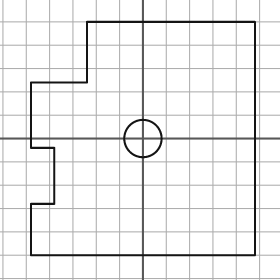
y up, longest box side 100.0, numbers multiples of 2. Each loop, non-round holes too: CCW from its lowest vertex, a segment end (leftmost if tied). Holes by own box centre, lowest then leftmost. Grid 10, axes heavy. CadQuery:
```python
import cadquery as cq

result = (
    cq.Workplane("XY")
    .moveTo(-48.0, -50.0)
    .lineTo(48.0, -50.0)
    .lineTo(48.0, 50.0)
    .lineTo(-24.0, 50.0)
    .lineTo(-24.0, 24.0)
    .lineTo(-48.0, 24.0)
    .lineTo(-48.0, -4.0)
    .lineTo(-38.0, -4.0)
    .lineTo(-38.0, -28.0)
    .lineTo(-48.0, -28.0)
    .close()
    .moveTo(0.0, 0.0)
    .circle(8.0)
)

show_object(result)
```